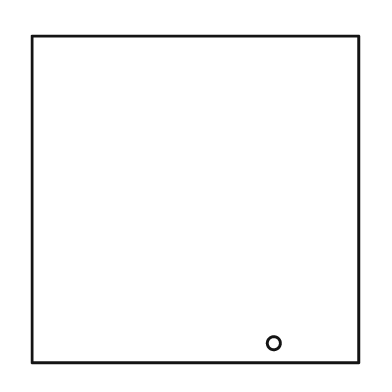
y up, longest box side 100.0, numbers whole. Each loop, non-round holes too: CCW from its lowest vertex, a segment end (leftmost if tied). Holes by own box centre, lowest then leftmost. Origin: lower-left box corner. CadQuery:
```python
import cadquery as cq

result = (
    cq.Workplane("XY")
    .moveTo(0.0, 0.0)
    .lineTo(100.0, 0.0)
    .lineTo(100.0, 100.0)
    .lineTo(0.0, 100.0)
    .close()
    .moveTo(74.0, 6.0)
    .circle(2.0)
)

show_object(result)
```